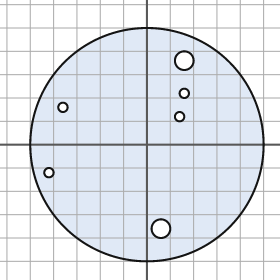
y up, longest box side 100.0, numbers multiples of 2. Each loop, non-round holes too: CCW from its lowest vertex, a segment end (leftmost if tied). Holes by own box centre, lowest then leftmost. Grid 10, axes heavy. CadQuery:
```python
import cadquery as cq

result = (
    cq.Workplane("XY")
    .moveTo(0.0, 0.0)
    .circle(50.0)
    .moveTo(6.0, -36.0)
    .circle(4.0)
    .moveTo(-42.0, -12.0)
    .circle(2.0)
    .moveTo(14.0, 12.0)
    .circle(2.0)
    .moveTo(-36.0, 16.0)
    .circle(2.0)
    .moveTo(16.0, 22.0)
    .circle(2.0)
    .moveTo(16.0, 36.0)
    .circle(4.0)
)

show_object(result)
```